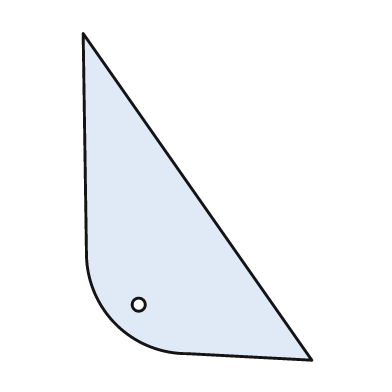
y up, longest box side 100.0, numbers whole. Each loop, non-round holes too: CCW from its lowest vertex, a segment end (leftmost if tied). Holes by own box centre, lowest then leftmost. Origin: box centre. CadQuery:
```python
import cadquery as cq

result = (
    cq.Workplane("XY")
    .moveTo(35.0, -50.0)
    .lineTo(-35.0, 50.0)
    .lineTo(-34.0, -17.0)
    .threePointArc((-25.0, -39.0), (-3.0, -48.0))
    .close()
    .moveTo(-18.0, -33.0)
    .circle(2.0)
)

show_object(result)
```